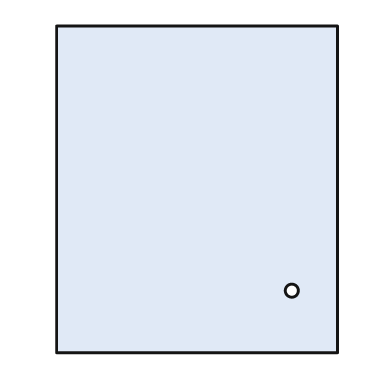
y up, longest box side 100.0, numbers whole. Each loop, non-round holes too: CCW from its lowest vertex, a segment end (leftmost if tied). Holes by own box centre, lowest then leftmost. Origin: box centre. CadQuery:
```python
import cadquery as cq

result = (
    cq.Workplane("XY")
    .moveTo(-43.0, -50.0)
    .lineTo(43.0, -50.0)
    .lineTo(43.0, 50.0)
    .lineTo(-43.0, 50.0)
    .close()
    .moveTo(29.0, -31.0)
    .circle(2.0)
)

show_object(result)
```